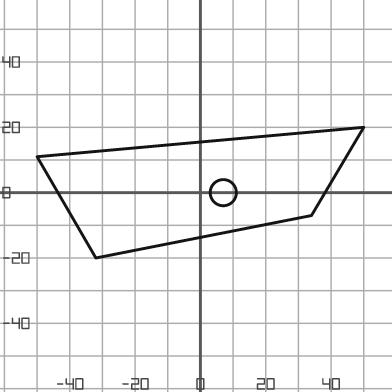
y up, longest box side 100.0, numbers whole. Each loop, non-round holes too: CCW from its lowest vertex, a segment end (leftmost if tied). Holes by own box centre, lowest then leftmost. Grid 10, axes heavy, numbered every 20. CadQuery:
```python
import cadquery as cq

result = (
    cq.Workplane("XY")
    .moveTo(-32.0, -20.0)
    .lineTo(34.0, -7.0)
    .lineTo(50.0, 20.0)
    .lineTo(-50.0, 11.0)
    .close()
    .moveTo(7.0, 0.0)
    .circle(4.0)
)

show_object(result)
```